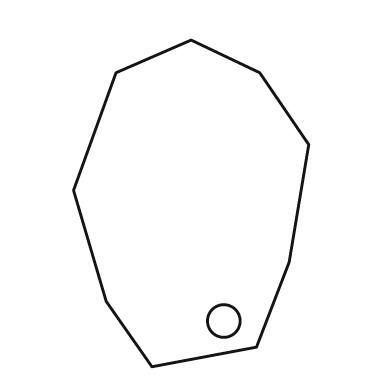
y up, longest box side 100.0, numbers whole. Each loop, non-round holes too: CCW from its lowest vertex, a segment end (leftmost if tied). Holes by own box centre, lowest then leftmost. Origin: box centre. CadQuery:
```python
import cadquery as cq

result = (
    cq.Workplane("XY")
    .moveTo(-12.0, -50.0)
    .lineTo(20.0, -44.0)
    .lineTo(30.0, -18.0)
    .lineTo(36.0, 18.0)
    .lineTo(21.0, 40.0)
    .lineTo(0.0, 50.0)
    .lineTo(-23.0, 40.0)
    .lineTo(-36.0, 4.0)
    .lineTo(-26.0, -30.0)
    .close()
    .moveTo(10.0, -36.0)
    .circle(5.0)
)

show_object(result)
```